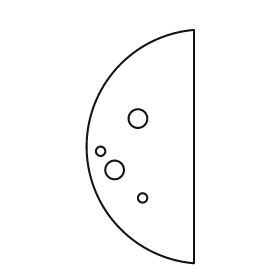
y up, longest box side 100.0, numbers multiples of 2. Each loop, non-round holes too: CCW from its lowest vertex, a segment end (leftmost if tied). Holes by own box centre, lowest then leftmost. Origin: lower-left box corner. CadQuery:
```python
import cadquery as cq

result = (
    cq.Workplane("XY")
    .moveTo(46.0, 0.0)
    .lineTo(46.0, 100.0)
    .threePointArc((0.0, 50.0), (46.0, 0.0))
    .close()
    .moveTo(24.0, 28.0)
    .circle(2.0)
    .moveTo(12.0, 40.0)
    .circle(4.0)
    .moveTo(6.0, 48.0)
    .circle(2.0)
    .moveTo(22.0, 62.0)
    .circle(4.0)
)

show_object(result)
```